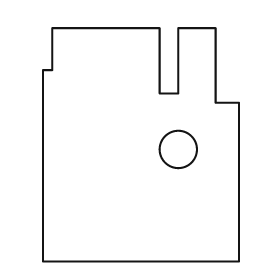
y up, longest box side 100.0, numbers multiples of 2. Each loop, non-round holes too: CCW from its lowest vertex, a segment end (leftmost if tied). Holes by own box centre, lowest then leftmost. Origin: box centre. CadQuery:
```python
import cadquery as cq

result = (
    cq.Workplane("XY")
    .moveTo(-42.0, -50.0)
    .lineTo(42.0, -50.0)
    .lineTo(42.0, 18.0)
    .lineTo(32.0, 18.0)
    .lineTo(32.0, 50.0)
    .lineTo(16.0, 50.0)
    .lineTo(16.0, 22.0)
    .lineTo(8.0, 22.0)
    .lineTo(8.0, 50.0)
    .lineTo(-38.0, 50.0)
    .lineTo(-38.0, 32.0)
    .lineTo(-42.0, 32.0)
    .close()
    .moveTo(16.0, -2.0)
    .circle(8.0)
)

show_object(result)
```